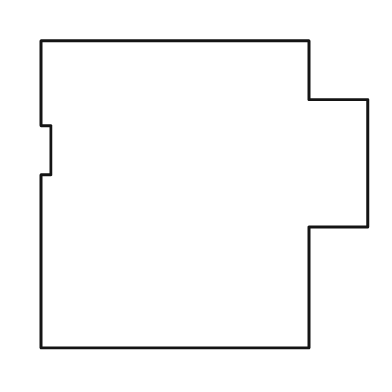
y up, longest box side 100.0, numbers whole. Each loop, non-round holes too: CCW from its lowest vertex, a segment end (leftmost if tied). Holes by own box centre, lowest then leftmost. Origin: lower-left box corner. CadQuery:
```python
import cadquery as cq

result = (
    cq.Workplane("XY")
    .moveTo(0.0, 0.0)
    .lineTo(82.0, 0.0)
    .lineTo(82.0, 37.0)
    .lineTo(100.0, 37.0)
    .lineTo(100.0, 76.0)
    .lineTo(82.0, 76.0)
    .lineTo(82.0, 94.0)
    .lineTo(0.0, 94.0)
    .lineTo(0.0, 68.0)
    .lineTo(3.0, 68.0)
    .lineTo(3.0, 53.0)
    .lineTo(0.0, 53.0)
    .close()
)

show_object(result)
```